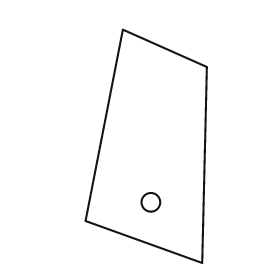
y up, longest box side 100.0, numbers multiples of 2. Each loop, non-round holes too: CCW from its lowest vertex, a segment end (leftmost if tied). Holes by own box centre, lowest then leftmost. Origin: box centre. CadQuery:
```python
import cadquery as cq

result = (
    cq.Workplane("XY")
    .moveTo(24.0, -50.0)
    .lineTo(26.0, 34.0)
    .lineTo(-10.0, 50.0)
    .lineTo(-26.0, -32.0)
    .close()
    .moveTo(2.0, -24.0)
    .circle(4.0)
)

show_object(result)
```